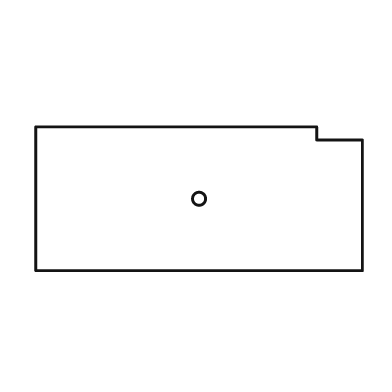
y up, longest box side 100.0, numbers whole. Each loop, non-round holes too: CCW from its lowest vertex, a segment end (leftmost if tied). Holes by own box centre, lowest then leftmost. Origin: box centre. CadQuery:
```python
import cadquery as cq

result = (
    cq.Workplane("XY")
    .moveTo(-50.0, -22.0)
    .lineTo(50.0, -22.0)
    .lineTo(50.0, 18.0)
    .lineTo(36.0, 18.0)
    .lineTo(36.0, 22.0)
    .lineTo(-50.0, 22.0)
    .close()
    .moveTo(0.0, 0.0)
    .circle(2.0)
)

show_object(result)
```